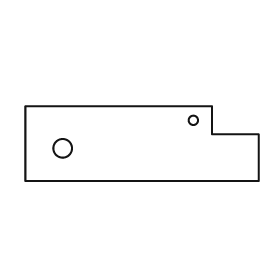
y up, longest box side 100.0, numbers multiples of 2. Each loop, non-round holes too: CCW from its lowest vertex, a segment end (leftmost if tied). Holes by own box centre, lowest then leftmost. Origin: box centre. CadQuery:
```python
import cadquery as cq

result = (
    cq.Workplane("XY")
    .moveTo(-50.0, -16.0)
    .lineTo(50.0, -16.0)
    .lineTo(50.0, 4.0)
    .lineTo(30.0, 4.0)
    .lineTo(30.0, 16.0)
    .lineTo(-50.0, 16.0)
    .close()
    .moveTo(-34.0, -2.0)
    .circle(4.0)
    .moveTo(22.0, 10.0)
    .circle(2.0)
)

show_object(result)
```